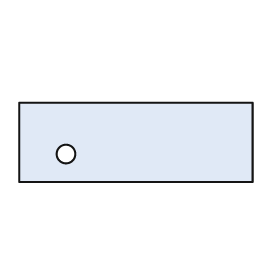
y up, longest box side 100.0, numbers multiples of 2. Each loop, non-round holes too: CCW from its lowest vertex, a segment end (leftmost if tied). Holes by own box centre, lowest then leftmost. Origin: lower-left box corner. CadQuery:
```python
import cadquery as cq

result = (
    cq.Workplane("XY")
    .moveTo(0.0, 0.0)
    .lineTo(100.0, 0.0)
    .lineTo(100.0, 34.0)
    .lineTo(0.0, 34.0)
    .close()
    .moveTo(20.0, 12.0)
    .circle(4.0)
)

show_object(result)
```